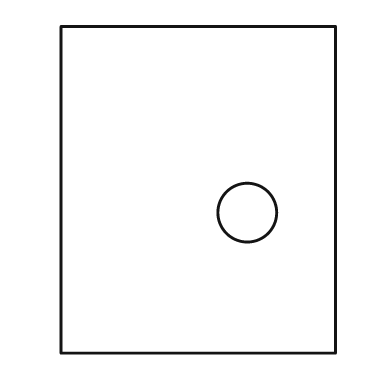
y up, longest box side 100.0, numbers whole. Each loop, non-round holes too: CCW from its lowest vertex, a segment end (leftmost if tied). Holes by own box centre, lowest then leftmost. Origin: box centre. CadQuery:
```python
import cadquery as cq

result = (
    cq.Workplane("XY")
    .moveTo(-42.0, -50.0)
    .lineTo(42.0, -50.0)
    .lineTo(42.0, 50.0)
    .lineTo(-42.0, 50.0)
    .close()
    .moveTo(15.0, -7.0)
    .circle(9.0)
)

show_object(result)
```